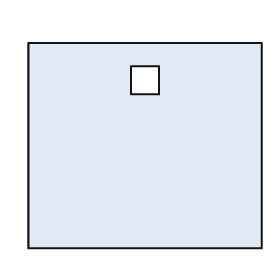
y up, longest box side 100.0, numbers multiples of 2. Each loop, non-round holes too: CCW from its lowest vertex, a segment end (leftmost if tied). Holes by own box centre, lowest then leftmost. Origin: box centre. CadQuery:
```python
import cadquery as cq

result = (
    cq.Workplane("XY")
    .moveTo(-50.0, -44.0)
    .lineTo(50.0, -44.0)
    .lineTo(50.0, 44.0)
    .lineTo(-50.0, 44.0)
    .close()
    .moveTo(-6.0, 22.0)
    .lineTo(6.0, 22.0)
    .lineTo(6.0, 34.0)
    .lineTo(-6.0, 34.0)
    .close()
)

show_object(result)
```